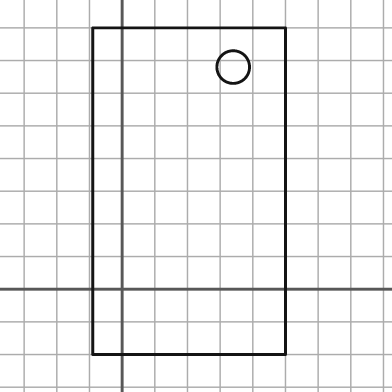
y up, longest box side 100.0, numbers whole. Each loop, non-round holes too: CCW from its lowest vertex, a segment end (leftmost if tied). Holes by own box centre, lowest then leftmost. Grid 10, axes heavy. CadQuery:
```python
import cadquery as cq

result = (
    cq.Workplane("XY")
    .moveTo(-9.0, -20.0)
    .lineTo(50.0, -20.0)
    .lineTo(50.0, 80.0)
    .lineTo(-9.0, 80.0)
    .close()
    .moveTo(34.0, 68.0)
    .circle(5.0)
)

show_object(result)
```